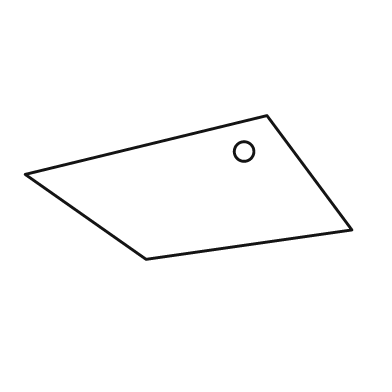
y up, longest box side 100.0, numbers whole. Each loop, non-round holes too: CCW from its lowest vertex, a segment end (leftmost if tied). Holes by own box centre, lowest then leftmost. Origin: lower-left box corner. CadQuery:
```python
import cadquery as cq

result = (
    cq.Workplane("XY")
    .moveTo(37.0, 0.0)
    .lineTo(100.0, 9.0)
    .lineTo(74.0, 44.0)
    .lineTo(0.0, 26.0)
    .close()
    .moveTo(67.0, 33.0)
    .circle(3.0)
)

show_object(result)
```